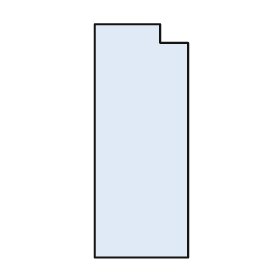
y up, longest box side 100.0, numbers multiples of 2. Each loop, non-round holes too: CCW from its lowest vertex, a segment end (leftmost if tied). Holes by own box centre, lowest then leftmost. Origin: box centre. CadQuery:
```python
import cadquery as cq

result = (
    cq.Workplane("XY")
    .moveTo(-20.0, -50.0)
    .lineTo(20.0, -50.0)
    .lineTo(20.0, 42.0)
    .lineTo(8.0, 42.0)
    .lineTo(8.0, 50.0)
    .lineTo(-20.0, 50.0)
    .close()
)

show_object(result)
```